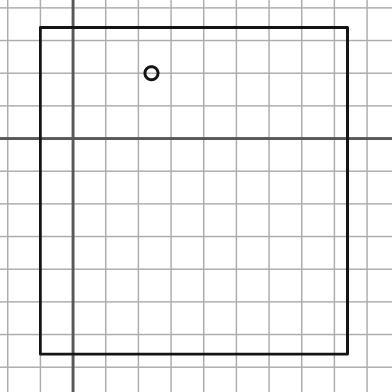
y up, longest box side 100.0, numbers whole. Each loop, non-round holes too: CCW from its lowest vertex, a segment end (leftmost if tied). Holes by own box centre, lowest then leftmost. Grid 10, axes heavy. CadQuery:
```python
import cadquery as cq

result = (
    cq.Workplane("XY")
    .moveTo(-10.0, -66.0)
    .lineTo(84.0, -66.0)
    .lineTo(84.0, 34.0)
    .lineTo(-10.0, 34.0)
    .close()
    .moveTo(24.0, 20.0)
    .circle(2.0)
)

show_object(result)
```